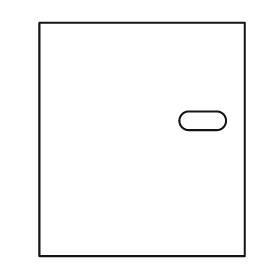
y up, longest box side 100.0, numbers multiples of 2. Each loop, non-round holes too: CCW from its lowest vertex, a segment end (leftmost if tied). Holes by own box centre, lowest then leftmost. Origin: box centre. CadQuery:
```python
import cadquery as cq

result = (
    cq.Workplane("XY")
    .moveTo(-44.0, -50.0)
    .lineTo(44.0, -50.0)
    .lineTo(44.0, 50.0)
    .lineTo(-44.0, 50.0)
    .close()
    .moveTo(20.0, 4.0)
    .lineTo(32.0, 4.0)
    .threePointArc((36.0, 8.0), (32.0, 12.0))
    .lineTo(20.0, 12.0)
    .threePointArc((16.0, 8.0), (20.0, 4.0))
    .close()
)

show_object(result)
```